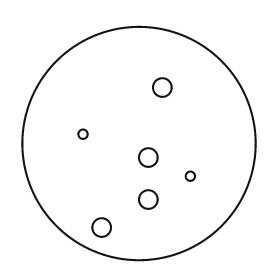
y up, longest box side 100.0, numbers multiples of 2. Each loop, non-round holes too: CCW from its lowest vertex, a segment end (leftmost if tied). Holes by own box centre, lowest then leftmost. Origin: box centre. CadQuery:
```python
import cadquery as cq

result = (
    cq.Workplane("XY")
    .moveTo(0.0, 0.0)
    .circle(50.0)
    .moveTo(-16.0, -36.0)
    .circle(4.0)
    .moveTo(4.0, -24.0)
    .circle(4.0)
    .moveTo(22.0, -14.0)
    .circle(2.0)
    .moveTo(4.0, -6.0)
    .circle(4.0)
    .moveTo(-24.0, 4.0)
    .circle(2.0)
    .moveTo(10.0, 24.0)
    .circle(4.0)
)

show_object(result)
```